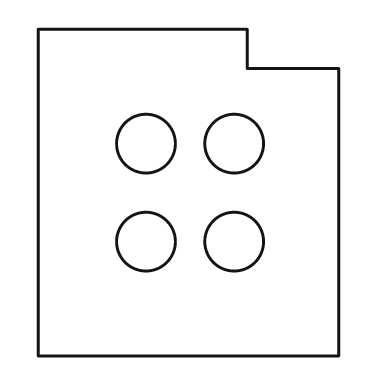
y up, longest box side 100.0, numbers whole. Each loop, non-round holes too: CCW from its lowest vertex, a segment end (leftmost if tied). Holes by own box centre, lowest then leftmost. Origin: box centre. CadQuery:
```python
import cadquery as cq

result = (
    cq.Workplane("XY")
    .moveTo(-46.0, -50.0)
    .lineTo(46.0, -50.0)
    .lineTo(46.0, 38.0)
    .lineTo(18.0, 38.0)
    .lineTo(18.0, 50.0)
    .lineTo(-46.0, 50.0)
    .close()
    .moveTo(-13.0, -15.0)
    .circle(9.0)
    .moveTo(14.0, -15.0)
    .circle(9.0)
    .moveTo(-13.0, 15.0)
    .circle(9.0)
    .moveTo(14.0, 15.0)
    .circle(9.0)
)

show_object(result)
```